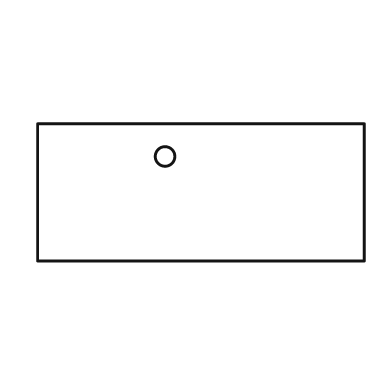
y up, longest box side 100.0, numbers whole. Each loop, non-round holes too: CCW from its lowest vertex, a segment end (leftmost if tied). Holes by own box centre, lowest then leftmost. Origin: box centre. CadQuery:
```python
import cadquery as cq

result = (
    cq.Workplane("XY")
    .moveTo(-50.0, -21.0)
    .lineTo(50.0, -21.0)
    .lineTo(50.0, 21.0)
    .lineTo(-50.0, 21.0)
    .close()
    .moveTo(-11.0, 11.0)
    .circle(3.0)
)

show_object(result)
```